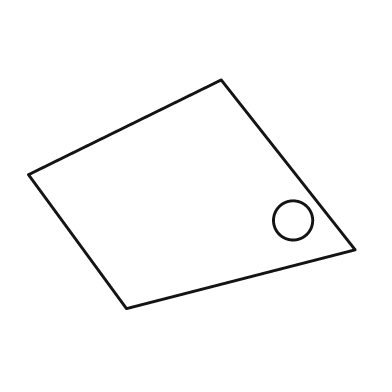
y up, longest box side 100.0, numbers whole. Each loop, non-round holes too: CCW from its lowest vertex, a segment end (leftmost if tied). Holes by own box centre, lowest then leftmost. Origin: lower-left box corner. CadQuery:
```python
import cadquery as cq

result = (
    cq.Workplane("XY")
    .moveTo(30.0, 0.0)
    .lineTo(100.0, 18.0)
    .lineTo(59.0, 70.0)
    .lineTo(0.0, 41.0)
    .close()
    .moveTo(81.0, 27.0)
    .circle(6.0)
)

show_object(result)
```